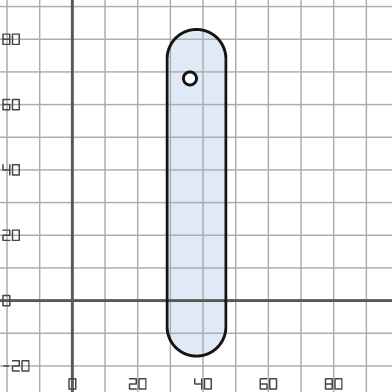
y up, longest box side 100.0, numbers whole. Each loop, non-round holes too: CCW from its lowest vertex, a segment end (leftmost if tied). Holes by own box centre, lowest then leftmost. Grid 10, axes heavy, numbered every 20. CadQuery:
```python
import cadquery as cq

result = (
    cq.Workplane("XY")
    .moveTo(29.0, -8.0)
    .threePointArc((38.0, -17.0), (47.0, -8.0))
    .lineTo(47.0, 74.0)
    .threePointArc((38.0, 83.0), (29.0, 74.0))
    .close()
    .moveTo(36.0, 68.0)
    .circle(2.0)
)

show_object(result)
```